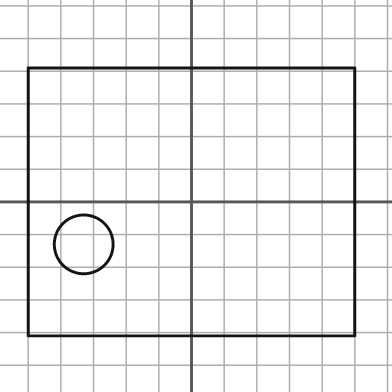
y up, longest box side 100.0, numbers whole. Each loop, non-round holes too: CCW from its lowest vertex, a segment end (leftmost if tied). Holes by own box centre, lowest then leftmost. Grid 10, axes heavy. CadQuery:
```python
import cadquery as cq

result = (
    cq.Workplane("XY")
    .moveTo(-50.0, -41.0)
    .lineTo(50.0, -41.0)
    .lineTo(50.0, 41.0)
    .lineTo(-50.0, 41.0)
    .close()
    .moveTo(-33.0, -13.0)
    .circle(9.0)
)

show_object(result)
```